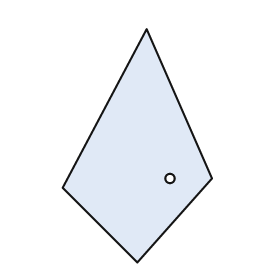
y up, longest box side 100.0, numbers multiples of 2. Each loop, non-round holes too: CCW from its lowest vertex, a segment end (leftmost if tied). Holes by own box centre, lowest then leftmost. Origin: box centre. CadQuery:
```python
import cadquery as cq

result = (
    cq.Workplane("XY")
    .moveTo(0.0, -50.0)
    .lineTo(32.0, -14.0)
    .lineTo(4.0, 50.0)
    .lineTo(-32.0, -18.0)
    .close()
    .moveTo(14.0, -14.0)
    .circle(2.0)
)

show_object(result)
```